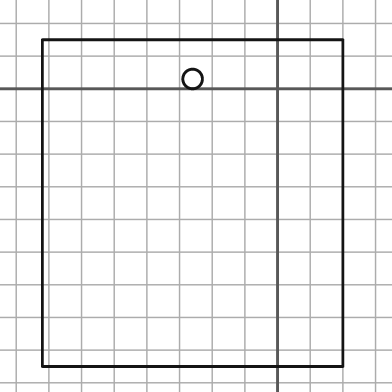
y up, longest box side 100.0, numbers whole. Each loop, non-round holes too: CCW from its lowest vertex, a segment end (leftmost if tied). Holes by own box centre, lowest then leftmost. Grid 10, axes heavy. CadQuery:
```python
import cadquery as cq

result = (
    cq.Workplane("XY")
    .moveTo(-72.0, -85.0)
    .lineTo(20.0, -85.0)
    .lineTo(20.0, 15.0)
    .lineTo(-72.0, 15.0)
    .close()
    .moveTo(-26.0, 3.0)
    .circle(3.0)
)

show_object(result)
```